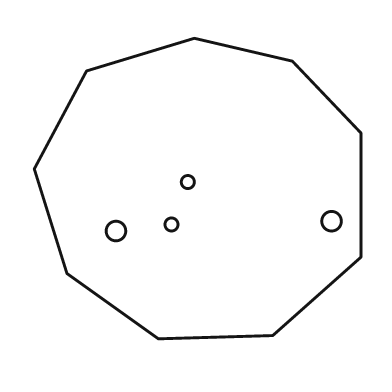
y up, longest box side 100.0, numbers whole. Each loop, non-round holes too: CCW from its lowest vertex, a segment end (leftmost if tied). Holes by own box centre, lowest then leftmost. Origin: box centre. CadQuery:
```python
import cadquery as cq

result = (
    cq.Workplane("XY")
    .moveTo(-12.0, -46.0)
    .lineTo(23.0, -45.0)
    .lineTo(50.0, -21.0)
    .lineTo(50.0, 17.0)
    .lineTo(29.0, 39.0)
    .lineTo(-1.0, 46.0)
    .lineTo(-34.0, 36.0)
    .lineTo(-50.0, 6.0)
    .lineTo(-40.0, -26.0)
    .close()
    .moveTo(-25.0, -13.0)
    .circle(3.0)
    .moveTo(-8.0, -11.0)
    .circle(2.0)
    .moveTo(41.0, -10.0)
    .circle(3.0)
    .moveTo(-3.0, 2.0)
    .circle(2.0)
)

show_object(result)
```